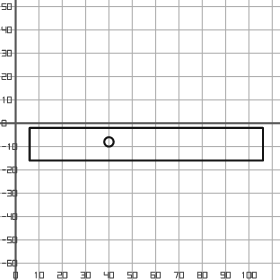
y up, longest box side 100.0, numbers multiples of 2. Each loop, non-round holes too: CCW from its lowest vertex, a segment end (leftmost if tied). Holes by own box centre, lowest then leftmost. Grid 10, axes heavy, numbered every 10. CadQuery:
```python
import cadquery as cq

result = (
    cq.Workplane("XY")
    .moveTo(6.0, -16.0)
    .lineTo(106.0, -16.0)
    .lineTo(106.0, -2.0)
    .lineTo(6.0, -2.0)
    .close()
    .moveTo(40.0, -8.0)
    .circle(2.0)
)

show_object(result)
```